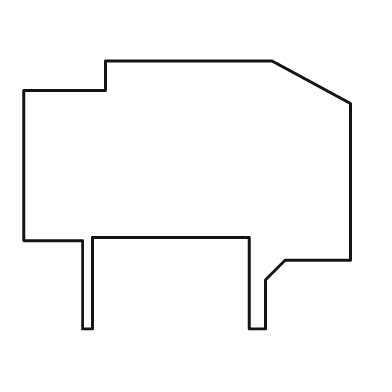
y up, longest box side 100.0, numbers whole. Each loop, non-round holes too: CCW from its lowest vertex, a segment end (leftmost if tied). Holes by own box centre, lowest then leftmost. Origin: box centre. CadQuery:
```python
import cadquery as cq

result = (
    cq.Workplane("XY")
    .moveTo(-32.0, -41.0)
    .lineTo(-29.0, -41.0)
    .lineTo(-29.0, -13.0)
    .lineTo(19.0, -13.0)
    .lineTo(19.0, -41.0)
    .lineTo(24.0, -41.0)
    .lineTo(24.0, -26.0)
    .lineTo(30.0, -20.0)
    .lineTo(50.0, -20.0)
    .lineTo(50.0, 28.0)
    .lineTo(26.0, 41.0)
    .lineTo(-25.0, 41.0)
    .lineTo(-25.0, 32.0)
    .lineTo(-50.0, 32.0)
    .lineTo(-50.0, -14.0)
    .lineTo(-32.0, -14.0)
    .close()
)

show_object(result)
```